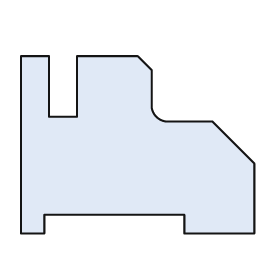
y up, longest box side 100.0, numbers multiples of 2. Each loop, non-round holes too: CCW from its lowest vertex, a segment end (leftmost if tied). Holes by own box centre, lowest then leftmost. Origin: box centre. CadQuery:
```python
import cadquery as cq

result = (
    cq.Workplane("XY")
    .moveTo(-50.0, -38.0)
    .lineTo(-40.0, -38.0)
    .lineTo(-40.0, -30.0)
    .lineTo(20.0, -30.0)
    .lineTo(20.0, -38.0)
    .lineTo(50.0, -38.0)
    .lineTo(50.0, -8.0)
    .lineTo(32.0, 10.0)
    .lineTo(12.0, 10.0)
    .threePointArc((8.0, 12.0), (6.0, 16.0))
    .lineTo(6.0, 32.0)
    .lineTo(0.0, 38.0)
    .lineTo(-26.0, 38.0)
    .lineTo(-26.0, 12.0)
    .lineTo(-38.0, 12.0)
    .lineTo(-38.0, 38.0)
    .lineTo(-50.0, 38.0)
    .close()
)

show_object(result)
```